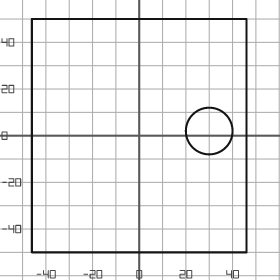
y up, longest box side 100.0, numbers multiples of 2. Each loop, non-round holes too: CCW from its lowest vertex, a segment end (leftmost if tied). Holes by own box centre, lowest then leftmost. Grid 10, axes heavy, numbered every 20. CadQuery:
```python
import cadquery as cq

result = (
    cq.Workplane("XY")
    .moveTo(-46.0, -50.0)
    .lineTo(46.0, -50.0)
    .lineTo(46.0, 50.0)
    .lineTo(-46.0, 50.0)
    .close()
    .moveTo(30.0, 2.0)
    .circle(10.0)
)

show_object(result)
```